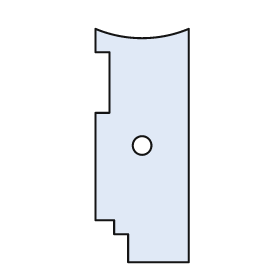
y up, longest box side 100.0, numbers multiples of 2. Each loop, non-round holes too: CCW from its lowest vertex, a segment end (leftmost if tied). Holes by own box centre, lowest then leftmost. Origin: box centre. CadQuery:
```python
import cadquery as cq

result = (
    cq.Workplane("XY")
    .moveTo(-6.0, -50.0)
    .lineTo(20.0, -50.0)
    .lineTo(20.0, 50.0)
    .threePointArc((0.0, 46.0), (-20.0, 50.0))
    .lineTo(-20.0, 40.0)
    .lineTo(-14.0, 40.0)
    .lineTo(-14.0, 14.0)
    .lineTo(-20.0, 14.0)
    .lineTo(-20.0, -32.0)
    .lineTo(-12.0, -32.0)
    .lineTo(-12.0, -38.0)
    .lineTo(-6.0, -38.0)
    .close()
    .moveTo(0.0, 0.0)
    .circle(4.0)
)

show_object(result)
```